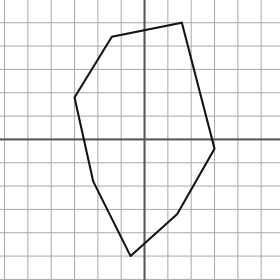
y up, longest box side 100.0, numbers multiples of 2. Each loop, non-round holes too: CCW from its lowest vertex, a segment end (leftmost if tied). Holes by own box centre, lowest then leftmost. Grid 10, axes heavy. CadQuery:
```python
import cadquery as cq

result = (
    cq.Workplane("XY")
    .moveTo(-6.0, -50.0)
    .lineTo(14.0, -32.0)
    .lineTo(30.0, -4.0)
    .lineTo(16.0, 50.0)
    .lineTo(-14.0, 44.0)
    .lineTo(-30.0, 18.0)
    .lineTo(-22.0, -18.0)
    .close()
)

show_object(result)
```